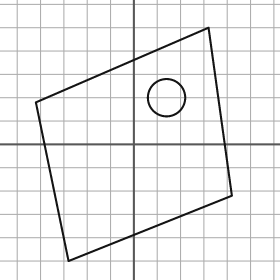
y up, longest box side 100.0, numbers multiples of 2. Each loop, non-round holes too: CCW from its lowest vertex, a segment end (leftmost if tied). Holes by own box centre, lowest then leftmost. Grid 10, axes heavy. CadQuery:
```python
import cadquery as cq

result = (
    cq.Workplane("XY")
    .moveTo(-28.0, -50.0)
    .lineTo(42.0, -22.0)
    .lineTo(32.0, 50.0)
    .lineTo(-42.0, 18.0)
    .close()
    .moveTo(14.0, 20.0)
    .circle(8.0)
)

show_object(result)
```